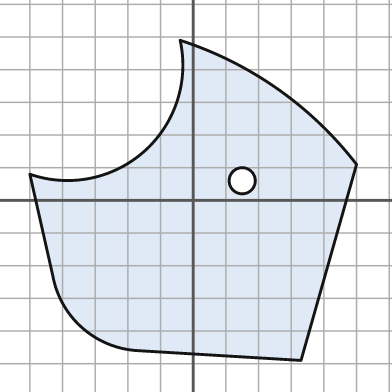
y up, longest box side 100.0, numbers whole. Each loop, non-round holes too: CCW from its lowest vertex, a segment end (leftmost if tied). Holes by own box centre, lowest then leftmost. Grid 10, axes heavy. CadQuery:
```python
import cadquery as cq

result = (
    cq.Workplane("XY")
    .moveTo(33.0, -49.0)
    .lineTo(50.0, 11.0)
    .threePointArc((26.0, 34.0), (-4.0, 49.0))
    .threePointArc((-15.0, 15.0), (-50.0, 8.0))
    .lineTo(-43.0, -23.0)
    .threePointArc((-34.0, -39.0), (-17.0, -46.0))
    .close()
    .moveTo(15.0, 6.0)
    .circle(4.0)
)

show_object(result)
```